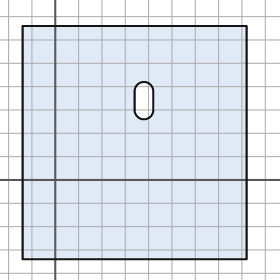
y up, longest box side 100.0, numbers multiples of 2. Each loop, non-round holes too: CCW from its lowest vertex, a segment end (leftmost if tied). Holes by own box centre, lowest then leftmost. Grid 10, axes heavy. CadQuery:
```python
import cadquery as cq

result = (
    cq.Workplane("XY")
    .moveTo(-14.0, -34.0)
    .lineTo(82.0, -34.0)
    .lineTo(82.0, 66.0)
    .lineTo(-14.0, 66.0)
    .close()
    .moveTo(34.0, 30.0)
    .threePointArc((38.0, 26.0), (42.0, 30.0))
    .lineTo(42.0, 38.0)
    .threePointArc((38.0, 42.0), (34.0, 38.0))
    .close()
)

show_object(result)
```